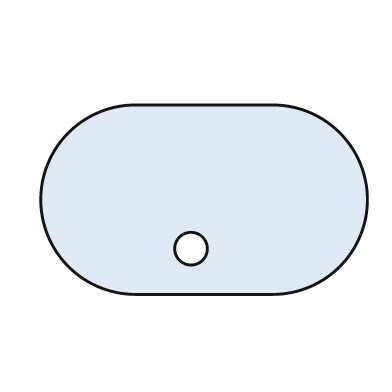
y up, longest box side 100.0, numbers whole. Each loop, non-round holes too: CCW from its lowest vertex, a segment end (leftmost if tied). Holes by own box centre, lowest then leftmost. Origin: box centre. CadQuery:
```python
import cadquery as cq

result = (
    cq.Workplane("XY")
    .moveTo(-21.0, -29.0)
    .lineTo(21.0, -29.0)
    .threePointArc((50.0, 0.0), (21.0, 29.0))
    .lineTo(-21.0, 29.0)
    .threePointArc((-50.0, 0.0), (-21.0, -29.0))
    .close()
    .moveTo(-4.0, -15.0)
    .circle(5.0)
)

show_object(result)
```